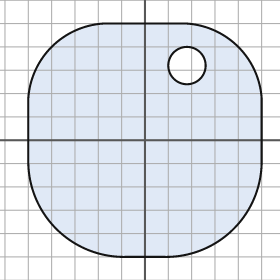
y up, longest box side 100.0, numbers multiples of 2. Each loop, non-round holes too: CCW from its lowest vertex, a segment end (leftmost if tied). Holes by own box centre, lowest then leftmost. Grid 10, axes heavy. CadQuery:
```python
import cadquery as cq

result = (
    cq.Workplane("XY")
    .moveTo(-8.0, -50.0)
    .lineTo(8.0, -50.0)
    .threePointArc((38.0, -38.0), (50.0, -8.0))
    .lineTo(50.0, 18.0)
    .threePointArc((40.0, 40.0), (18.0, 50.0))
    .lineTo(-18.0, 50.0)
    .threePointArc((-40.0, 40.0), (-50.0, 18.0))
    .lineTo(-50.0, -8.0)
    .threePointArc((-38.0, -38.0), (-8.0, -50.0))
    .close()
    .moveTo(18.0, 32.0)
    .circle(8.0)
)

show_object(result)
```